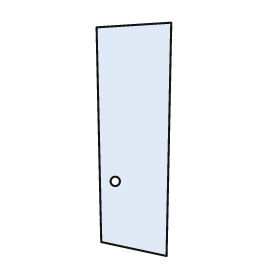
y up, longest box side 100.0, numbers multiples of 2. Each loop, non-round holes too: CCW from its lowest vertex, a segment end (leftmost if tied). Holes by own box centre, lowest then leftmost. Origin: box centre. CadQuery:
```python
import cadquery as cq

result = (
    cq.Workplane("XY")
    .moveTo(14.0, -50.0)
    .lineTo(16.0, 50.0)
    .lineTo(-16.0, 48.0)
    .lineTo(-14.0, -44.0)
    .close()
    .moveTo(-8.0, -18.0)
    .circle(2.0)
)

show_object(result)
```